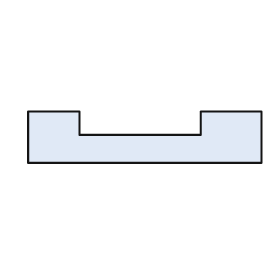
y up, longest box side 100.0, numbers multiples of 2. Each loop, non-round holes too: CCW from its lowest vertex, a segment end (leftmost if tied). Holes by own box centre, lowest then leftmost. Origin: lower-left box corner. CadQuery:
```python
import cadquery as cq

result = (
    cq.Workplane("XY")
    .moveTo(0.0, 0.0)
    .lineTo(100.0, 0.0)
    .lineTo(100.0, 22.0)
    .lineTo(74.0, 22.0)
    .lineTo(74.0, 12.0)
    .lineTo(22.0, 12.0)
    .lineTo(22.0, 22.0)
    .lineTo(0.0, 22.0)
    .close()
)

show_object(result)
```